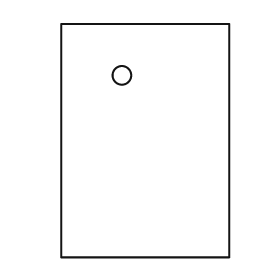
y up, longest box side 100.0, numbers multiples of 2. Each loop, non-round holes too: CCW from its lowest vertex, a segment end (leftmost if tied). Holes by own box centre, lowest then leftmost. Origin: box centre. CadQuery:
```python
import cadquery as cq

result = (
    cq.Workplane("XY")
    .moveTo(-36.0, -50.0)
    .lineTo(36.0, -50.0)
    .lineTo(36.0, 50.0)
    .lineTo(-36.0, 50.0)
    .close()
    .moveTo(-10.0, 28.0)
    .circle(4.0)
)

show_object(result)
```